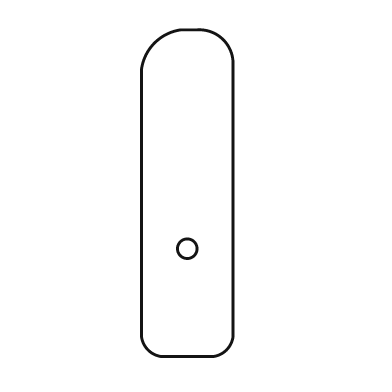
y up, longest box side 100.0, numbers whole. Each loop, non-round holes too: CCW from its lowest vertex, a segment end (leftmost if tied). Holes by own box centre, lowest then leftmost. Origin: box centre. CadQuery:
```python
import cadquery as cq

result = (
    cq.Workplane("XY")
    .moveTo(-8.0, -50.0)
    .lineTo(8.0, -50.0)
    .threePointArc((12.0, -48.0), (14.0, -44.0))
    .lineTo(14.0, 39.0)
    .threePointArc((11.0, 47.0), (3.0, 50.0))
    .lineTo(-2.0, 50.0)
    .threePointArc((-10.0, 46.0), (-14.0, 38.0))
    .lineTo(-14.0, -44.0)
    .threePointArc((-12.0, -48.0), (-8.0, -50.0))
    .close()
    .moveTo(0.0, -17.0)
    .circle(3.0)
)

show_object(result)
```